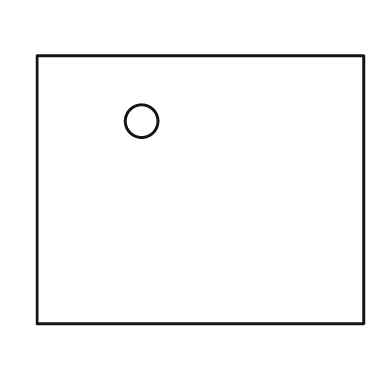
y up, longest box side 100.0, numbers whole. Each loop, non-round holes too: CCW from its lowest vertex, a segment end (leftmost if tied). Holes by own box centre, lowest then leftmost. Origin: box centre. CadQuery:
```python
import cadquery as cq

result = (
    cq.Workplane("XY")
    .moveTo(-50.0, -41.0)
    .lineTo(50.0, -41.0)
    .lineTo(50.0, 41.0)
    .lineTo(-50.0, 41.0)
    .close()
    .moveTo(-18.0, 21.0)
    .circle(5.0)
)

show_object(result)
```